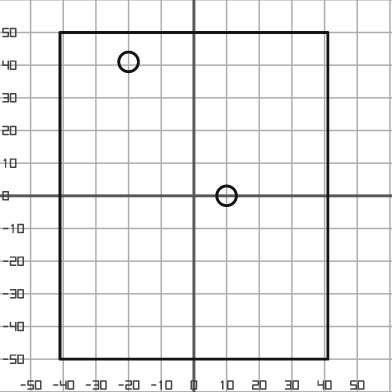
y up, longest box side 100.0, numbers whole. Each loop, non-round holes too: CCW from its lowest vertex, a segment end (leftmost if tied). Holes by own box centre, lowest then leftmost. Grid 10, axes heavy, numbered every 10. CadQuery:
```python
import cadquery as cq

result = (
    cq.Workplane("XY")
    .moveTo(-41.0, -50.0)
    .lineTo(41.0, -50.0)
    .lineTo(41.0, 50.0)
    .lineTo(-41.0, 50.0)
    .close()
    .moveTo(10.0, 0.0)
    .circle(3.0)
    .moveTo(-20.0, 41.0)
    .circle(3.0)
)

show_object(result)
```